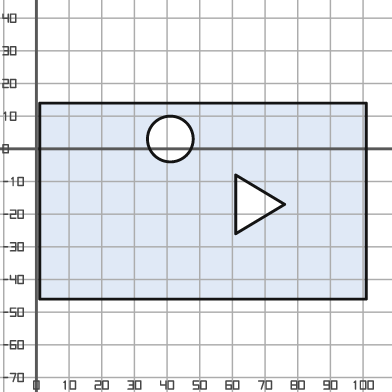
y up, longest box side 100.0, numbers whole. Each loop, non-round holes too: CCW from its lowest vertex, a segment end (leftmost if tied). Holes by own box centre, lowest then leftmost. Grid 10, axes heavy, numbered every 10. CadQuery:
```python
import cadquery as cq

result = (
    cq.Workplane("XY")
    .moveTo(1.0, -46.0)
    .lineTo(101.0, -46.0)
    .lineTo(101.0, 14.0)
    .lineTo(1.0, 14.0)
    .close()
    .moveTo(61.0, -26.0)
    .lineTo(76.0, -17.0)
    .lineTo(61.0, -8.0)
    .close()
    .moveTo(41.0, 3.0)
    .circle(7.0)
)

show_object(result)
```